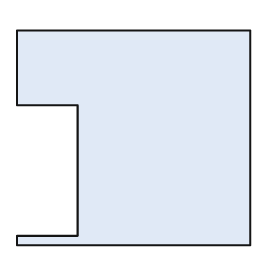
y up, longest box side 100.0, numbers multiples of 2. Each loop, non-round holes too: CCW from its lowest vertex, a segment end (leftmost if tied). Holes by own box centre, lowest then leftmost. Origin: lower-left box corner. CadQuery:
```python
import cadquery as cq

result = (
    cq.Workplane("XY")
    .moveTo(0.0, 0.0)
    .lineTo(100.0, 0.0)
    .lineTo(100.0, 92.0)
    .lineTo(0.0, 92.0)
    .lineTo(0.0, 60.0)
    .lineTo(26.0, 60.0)
    .lineTo(26.0, 4.0)
    .lineTo(0.0, 4.0)
    .close()
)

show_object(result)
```